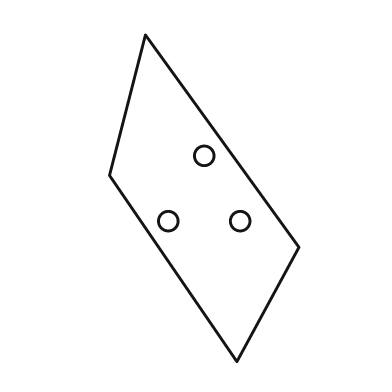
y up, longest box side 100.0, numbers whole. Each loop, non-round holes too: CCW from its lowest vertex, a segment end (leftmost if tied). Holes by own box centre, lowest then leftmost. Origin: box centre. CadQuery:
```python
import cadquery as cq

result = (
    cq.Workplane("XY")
    .moveTo(10.0, -50.0)
    .lineTo(29.0, -15.0)
    .lineTo(-18.0, 50.0)
    .lineTo(-29.0, 7.0)
    .close()
    .moveTo(-11.0, -7.0)
    .circle(3.0)
    .moveTo(11.0, -7.0)
    .circle(3.0)
    .moveTo(0.0, 13.0)
    .circle(3.0)
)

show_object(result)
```